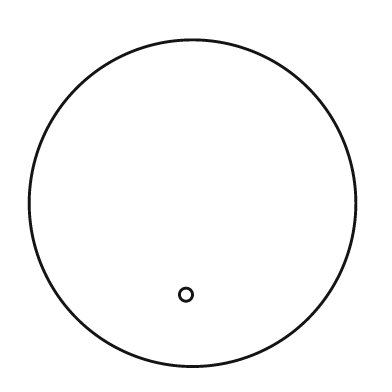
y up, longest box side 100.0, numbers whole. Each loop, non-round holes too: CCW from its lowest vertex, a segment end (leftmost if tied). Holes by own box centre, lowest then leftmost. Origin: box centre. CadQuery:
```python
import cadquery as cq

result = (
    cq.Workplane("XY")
    .moveTo(0.0, 0.0)
    .circle(50.0)
    .moveTo(-2.0, -28.0)
    .circle(2.0)
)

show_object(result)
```